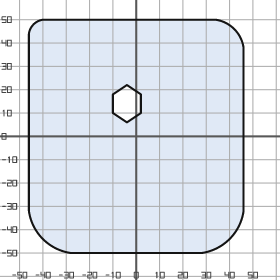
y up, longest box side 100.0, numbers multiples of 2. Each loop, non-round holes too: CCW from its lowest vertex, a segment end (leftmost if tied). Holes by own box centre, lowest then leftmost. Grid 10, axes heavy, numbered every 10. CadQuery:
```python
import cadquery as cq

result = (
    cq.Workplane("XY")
    .moveTo(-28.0, -50.0)
    .lineTo(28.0, -50.0)
    .threePointArc((40.0, -44.0), (46.0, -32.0))
    .lineTo(46.0, 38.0)
    .threePointArc((42.0, 46.0), (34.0, 50.0))
    .lineTo(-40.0, 50.0)
    .threePointArc((-44.0, 48.0), (-46.0, 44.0))
    .lineTo(-46.0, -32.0)
    .threePointArc((-40.0, -44.0), (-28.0, -50.0))
    .close()
    .moveTo(-4.0, 6.0)
    .lineTo(2.0, 10.0)
    .lineTo(2.0, 18.0)
    .lineTo(-4.0, 22.0)
    .lineTo(-10.0, 18.0)
    .lineTo(-10.0, 10.0)
    .close()
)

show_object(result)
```